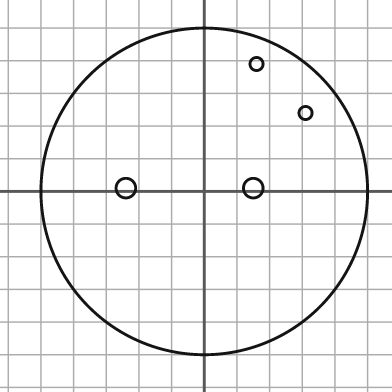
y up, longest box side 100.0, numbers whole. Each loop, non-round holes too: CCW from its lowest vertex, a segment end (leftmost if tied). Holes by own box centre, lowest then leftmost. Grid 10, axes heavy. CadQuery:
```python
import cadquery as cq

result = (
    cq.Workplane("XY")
    .moveTo(0.0, 0.0)
    .circle(50.0)
    .moveTo(-24.0, 1.0)
    .circle(3.0)
    .moveTo(15.0, 1.0)
    .circle(3.0)
    .moveTo(31.0, 24.0)
    .circle(2.0)
    .moveTo(16.0, 39.0)
    .circle(2.0)
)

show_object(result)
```